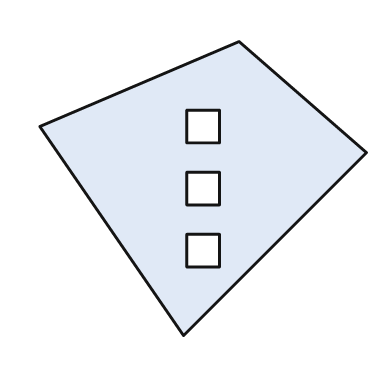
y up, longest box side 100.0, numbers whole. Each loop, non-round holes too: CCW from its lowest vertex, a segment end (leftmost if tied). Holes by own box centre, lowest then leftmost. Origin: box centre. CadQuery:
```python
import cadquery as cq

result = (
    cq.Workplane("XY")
    .moveTo(-6.0, -45.0)
    .lineTo(50.0, 11.0)
    .lineTo(11.0, 45.0)
    .lineTo(-50.0, 19.0)
    .close()
    .moveTo(-5.0, -24.0)
    .lineTo(5.0, -24.0)
    .lineTo(5.0, -14.0)
    .lineTo(-5.0, -14.0)
    .close()
    .moveTo(-5.0, -5.0)
    .lineTo(5.0, -5.0)
    .lineTo(5.0, 5.0)
    .lineTo(-5.0, 5.0)
    .close()
    .moveTo(-5.0, 14.0)
    .lineTo(5.0, 14.0)
    .lineTo(5.0, 24.0)
    .lineTo(-5.0, 24.0)
    .close()
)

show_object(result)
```